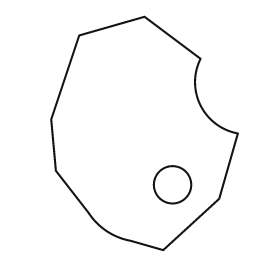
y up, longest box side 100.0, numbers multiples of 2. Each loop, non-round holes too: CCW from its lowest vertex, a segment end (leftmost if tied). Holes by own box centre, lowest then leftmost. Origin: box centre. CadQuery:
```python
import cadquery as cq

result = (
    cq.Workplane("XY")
    .moveTo(8.0, -50.0)
    .lineTo(32.0, -28.0)
    .lineTo(40.0, 0.0)
    .threePointArc((24.0, 12.0), (24.0, 32.0))
    .lineTo(0.0, 50.0)
    .lineTo(-28.0, 42.0)
    .lineTo(-40.0, 6.0)
    .lineTo(-38.0, -16.0)
    .lineTo(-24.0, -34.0)
    .threePointArc((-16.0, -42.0), (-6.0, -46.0))
    .close()
    .moveTo(12.0, -22.0)
    .circle(8.0)
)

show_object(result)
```